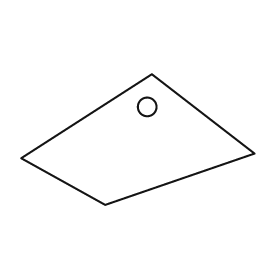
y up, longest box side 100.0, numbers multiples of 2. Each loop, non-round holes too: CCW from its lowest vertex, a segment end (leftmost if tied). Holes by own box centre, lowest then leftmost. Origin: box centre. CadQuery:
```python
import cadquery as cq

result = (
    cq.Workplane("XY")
    .moveTo(-14.0, -28.0)
    .lineTo(50.0, -6.0)
    .lineTo(6.0, 28.0)
    .lineTo(-50.0, -8.0)
    .close()
    .moveTo(4.0, 14.0)
    .circle(4.0)
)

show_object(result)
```